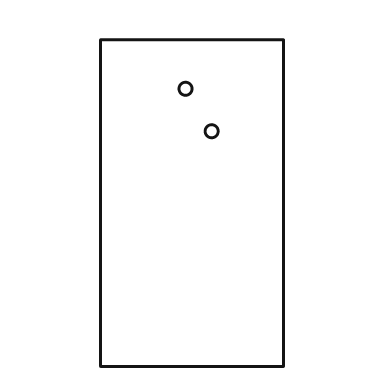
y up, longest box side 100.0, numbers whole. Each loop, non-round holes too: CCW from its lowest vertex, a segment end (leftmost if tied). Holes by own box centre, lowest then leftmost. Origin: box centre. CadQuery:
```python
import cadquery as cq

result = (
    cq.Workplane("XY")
    .moveTo(-28.0, -50.0)
    .lineTo(28.0, -50.0)
    .lineTo(28.0, 50.0)
    .lineTo(-28.0, 50.0)
    .close()
    .moveTo(6.0, 22.0)
    .circle(2.0)
    .moveTo(-2.0, 35.0)
    .circle(2.0)
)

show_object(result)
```